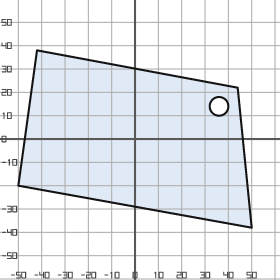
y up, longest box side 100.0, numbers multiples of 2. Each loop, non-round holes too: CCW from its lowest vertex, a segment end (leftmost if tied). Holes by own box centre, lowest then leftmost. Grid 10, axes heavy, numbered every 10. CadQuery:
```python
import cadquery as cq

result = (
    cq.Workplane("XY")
    .moveTo(50.0, -38.0)
    .lineTo(44.0, 22.0)
    .lineTo(-42.0, 38.0)
    .lineTo(-50.0, -20.0)
    .close()
    .moveTo(36.0, 14.0)
    .circle(4.0)
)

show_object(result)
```